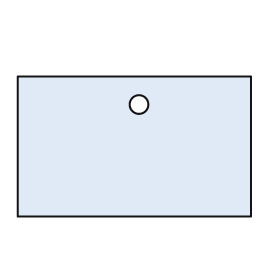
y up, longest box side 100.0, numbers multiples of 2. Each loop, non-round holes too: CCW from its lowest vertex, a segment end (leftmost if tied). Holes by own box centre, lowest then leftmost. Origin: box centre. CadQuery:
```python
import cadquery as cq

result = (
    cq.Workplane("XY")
    .moveTo(-50.0, -30.0)
    .lineTo(50.0, -30.0)
    .lineTo(50.0, 30.0)
    .lineTo(-50.0, 30.0)
    .close()
    .moveTo(2.0, 18.0)
    .circle(4.0)
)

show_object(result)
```